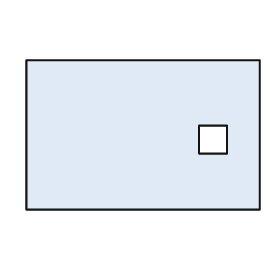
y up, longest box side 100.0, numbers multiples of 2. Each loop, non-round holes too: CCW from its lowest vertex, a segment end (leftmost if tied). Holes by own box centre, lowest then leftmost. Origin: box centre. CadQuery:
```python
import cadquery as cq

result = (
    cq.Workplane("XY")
    .moveTo(-50.0, -32.0)
    .lineTo(50.0, -32.0)
    .lineTo(50.0, 32.0)
    .lineTo(-50.0, 32.0)
    .close()
    .moveTo(24.0, -8.0)
    .lineTo(36.0, -8.0)
    .lineTo(36.0, 4.0)
    .lineTo(24.0, 4.0)
    .close()
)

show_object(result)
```